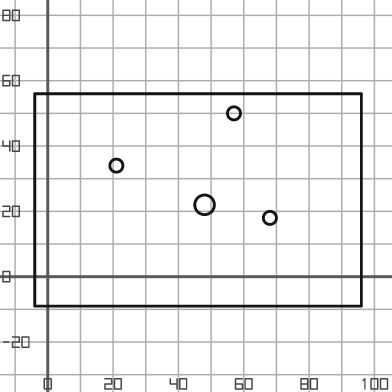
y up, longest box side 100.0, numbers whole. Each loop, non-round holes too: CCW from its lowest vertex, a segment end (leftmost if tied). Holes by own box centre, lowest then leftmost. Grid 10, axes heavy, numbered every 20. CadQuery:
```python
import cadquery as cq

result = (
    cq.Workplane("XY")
    .moveTo(-4.0, -9.0)
    .lineTo(96.0, -9.0)
    .lineTo(96.0, 56.0)
    .lineTo(-4.0, 56.0)
    .close()
    .moveTo(68.0, 18.0)
    .circle(2.0)
    .moveTo(48.0, 22.0)
    .circle(3.0)
    .moveTo(21.0, 34.0)
    .circle(2.0)
    .moveTo(57.0, 50.0)
    .circle(2.0)
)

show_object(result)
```